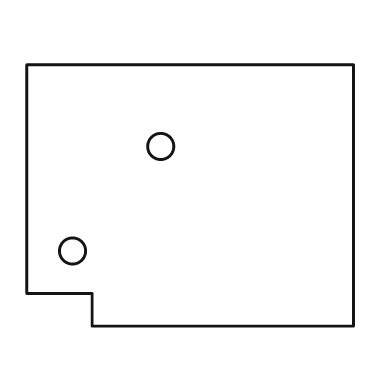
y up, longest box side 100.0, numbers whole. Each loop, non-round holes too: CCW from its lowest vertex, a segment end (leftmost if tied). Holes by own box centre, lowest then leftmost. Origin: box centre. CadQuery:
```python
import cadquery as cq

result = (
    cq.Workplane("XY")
    .moveTo(-30.0, -40.0)
    .lineTo(50.0, -40.0)
    .lineTo(50.0, 40.0)
    .lineTo(-50.0, 40.0)
    .lineTo(-50.0, -30.0)
    .lineTo(-30.0, -30.0)
    .close()
    .moveTo(-36.0, -17.0)
    .circle(4.0)
    .moveTo(-9.0, 15.0)
    .circle(4.0)
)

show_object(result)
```